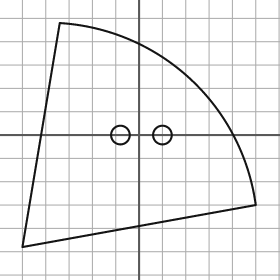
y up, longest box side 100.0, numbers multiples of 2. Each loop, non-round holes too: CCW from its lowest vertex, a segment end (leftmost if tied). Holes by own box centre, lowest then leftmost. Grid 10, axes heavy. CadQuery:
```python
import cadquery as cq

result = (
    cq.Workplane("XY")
    .moveTo(-50.0, -48.0)
    .lineTo(50.0, -30.0)
    .threePointArc((22.0, 24.0), (-34.0, 48.0))
    .close()
    .moveTo(-8.0, 0.0)
    .circle(4.0)
    .moveTo(10.0, 0.0)
    .circle(4.0)
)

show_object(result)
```